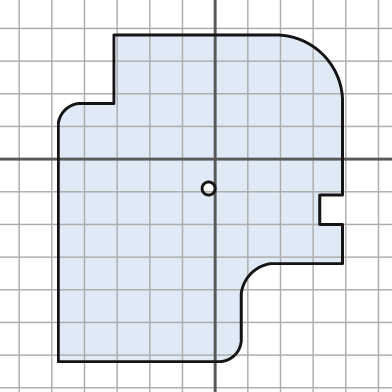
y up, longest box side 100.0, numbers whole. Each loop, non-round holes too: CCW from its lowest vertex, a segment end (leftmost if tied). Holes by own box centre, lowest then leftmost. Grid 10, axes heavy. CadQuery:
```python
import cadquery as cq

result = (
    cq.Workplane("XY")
    .moveTo(-48.0, -62.0)
    .lineTo(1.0, -62.0)
    .threePointArc((6.0, -60.0), (8.0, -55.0))
    .lineTo(8.0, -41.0)
    .threePointArc((11.0, -35.0), (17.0, -32.0))
    .lineTo(39.0, -32.0)
    .lineTo(39.0, -20.0)
    .lineTo(32.0, -20.0)
    .lineTo(32.0, -11.0)
    .lineTo(39.0, -11.0)
    .lineTo(39.0, 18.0)
    .threePointArc((33.0, 32.0), (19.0, 38.0))
    .lineTo(-31.0, 38.0)
    .lineTo(-31.0, 17.0)
    .lineTo(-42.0, 17.0)
    .threePointArc((-46.0, 15.0), (-48.0, 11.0))
    .close()
    .moveTo(-2.0, -9.0)
    .circle(2.0)
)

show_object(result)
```